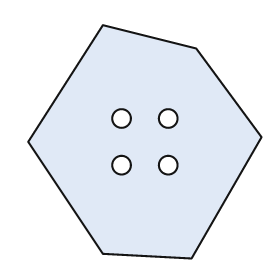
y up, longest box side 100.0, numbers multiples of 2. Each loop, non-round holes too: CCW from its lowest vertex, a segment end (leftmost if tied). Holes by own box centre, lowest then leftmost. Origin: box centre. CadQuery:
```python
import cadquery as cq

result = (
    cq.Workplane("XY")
    .moveTo(20.0, -50.0)
    .lineTo(50.0, 2.0)
    .lineTo(22.0, 40.0)
    .lineTo(-18.0, 50.0)
    .lineTo(-50.0, 0.0)
    .lineTo(-18.0, -48.0)
    .close()
    .moveTo(-10.0, -10.0)
    .circle(4.0)
    .moveTo(10.0, -10.0)
    .circle(4.0)
    .moveTo(-10.0, 10.0)
    .circle(4.0)
    .moveTo(10.0, 10.0)
    .circle(4.0)
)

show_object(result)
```